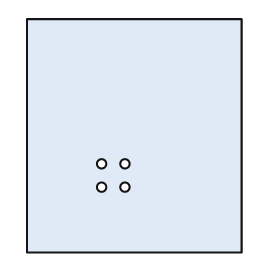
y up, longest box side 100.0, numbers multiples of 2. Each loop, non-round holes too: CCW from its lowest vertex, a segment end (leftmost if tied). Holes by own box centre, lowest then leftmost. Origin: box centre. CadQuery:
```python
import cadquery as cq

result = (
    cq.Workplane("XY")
    .moveTo(-46.0, -50.0)
    .lineTo(46.0, -50.0)
    .lineTo(46.0, 50.0)
    .lineTo(-46.0, 50.0)
    .close()
    .moveTo(-14.0, -22.0)
    .circle(2.0)
    .moveTo(-4.0, -22.0)
    .circle(2.0)
    .moveTo(-14.0, -12.0)
    .circle(2.0)
    .moveTo(-4.0, -12.0)
    .circle(2.0)
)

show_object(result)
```